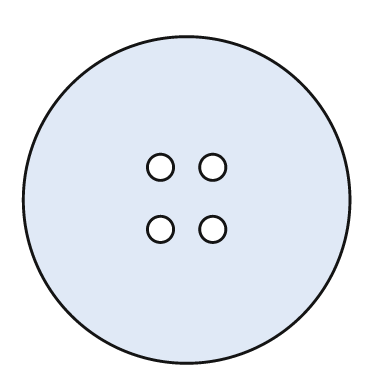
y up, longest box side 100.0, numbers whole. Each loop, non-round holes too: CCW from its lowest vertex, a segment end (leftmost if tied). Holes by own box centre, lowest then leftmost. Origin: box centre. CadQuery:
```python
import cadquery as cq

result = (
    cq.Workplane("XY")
    .moveTo(0.0, 0.0)
    .circle(50.0)
    .moveTo(-8.0, -9.0)
    .circle(4.0)
    .moveTo(8.0, -9.0)
    .circle(4.0)
    .moveTo(-8.0, 10.0)
    .circle(4.0)
    .moveTo(8.0, 10.0)
    .circle(4.0)
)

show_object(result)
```